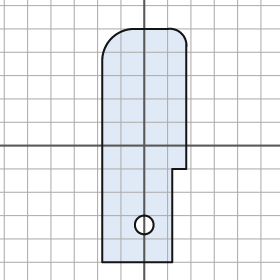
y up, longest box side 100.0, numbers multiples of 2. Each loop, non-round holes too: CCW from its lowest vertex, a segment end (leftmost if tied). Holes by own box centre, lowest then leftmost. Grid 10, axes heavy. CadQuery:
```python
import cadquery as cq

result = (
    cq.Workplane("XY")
    .moveTo(-18.0, -50.0)
    .lineTo(12.0, -50.0)
    .lineTo(12.0, -10.0)
    .lineTo(18.0, -10.0)
    .lineTo(18.0, 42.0)
    .threePointArc((16.0, 48.0), (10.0, 50.0))
    .lineTo(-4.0, 50.0)
    .threePointArc((-14.0, 46.0), (-18.0, 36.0))
    .close()
    .moveTo(0.0, -34.0)
    .circle(4.0)
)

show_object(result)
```